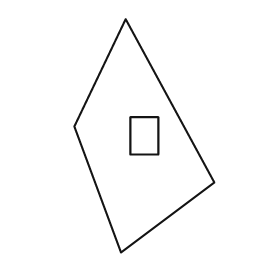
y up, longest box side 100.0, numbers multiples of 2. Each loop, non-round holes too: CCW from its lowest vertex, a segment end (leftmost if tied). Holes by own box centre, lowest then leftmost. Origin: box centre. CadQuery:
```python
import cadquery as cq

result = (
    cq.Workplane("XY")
    .moveTo(-10.0, -50.0)
    .lineTo(30.0, -20.0)
    .lineTo(-8.0, 50.0)
    .lineTo(-30.0, 4.0)
    .close()
    .moveTo(-6.0, -8.0)
    .lineTo(6.0, -8.0)
    .lineTo(6.0, 8.0)
    .lineTo(-6.0, 8.0)
    .close()
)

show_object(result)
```